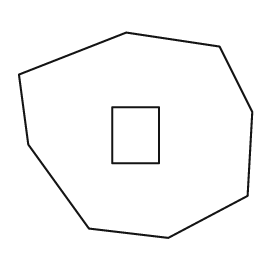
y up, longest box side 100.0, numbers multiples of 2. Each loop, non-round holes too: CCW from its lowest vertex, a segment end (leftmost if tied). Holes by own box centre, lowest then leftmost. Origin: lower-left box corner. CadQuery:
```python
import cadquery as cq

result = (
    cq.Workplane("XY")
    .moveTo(64.0, 0.0)
    .lineTo(98.0, 18.0)
    .lineTo(100.0, 54.0)
    .lineTo(86.0, 82.0)
    .lineTo(46.0, 88.0)
    .lineTo(0.0, 70.0)
    .lineTo(4.0, 40.0)
    .lineTo(30.0, 4.0)
    .close()
    .moveTo(40.0, 32.0)
    .lineTo(60.0, 32.0)
    .lineTo(60.0, 56.0)
    .lineTo(40.0, 56.0)
    .close()
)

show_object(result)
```